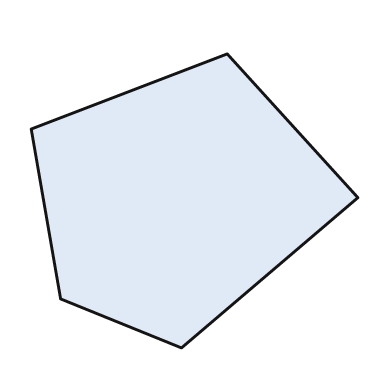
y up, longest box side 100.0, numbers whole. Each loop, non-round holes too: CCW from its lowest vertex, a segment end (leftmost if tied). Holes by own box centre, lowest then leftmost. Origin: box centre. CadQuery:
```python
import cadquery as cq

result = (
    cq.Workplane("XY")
    .moveTo(-4.0, -45.0)
    .lineTo(50.0, 1.0)
    .lineTo(10.0, 45.0)
    .lineTo(-50.0, 22.0)
    .lineTo(-41.0, -30.0)
    .close()
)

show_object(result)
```